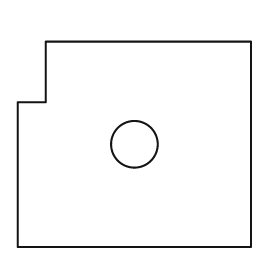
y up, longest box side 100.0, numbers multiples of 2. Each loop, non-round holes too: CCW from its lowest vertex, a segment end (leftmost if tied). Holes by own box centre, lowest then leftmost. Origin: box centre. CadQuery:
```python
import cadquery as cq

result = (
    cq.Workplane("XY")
    .moveTo(-50.0, -44.0)
    .lineTo(50.0, -44.0)
    .lineTo(50.0, 44.0)
    .lineTo(-38.0, 44.0)
    .lineTo(-38.0, 18.0)
    .lineTo(-50.0, 18.0)
    .close()
    .moveTo(0.0, 0.0)
    .circle(10.0)
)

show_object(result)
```